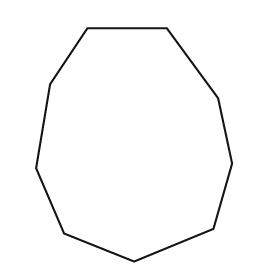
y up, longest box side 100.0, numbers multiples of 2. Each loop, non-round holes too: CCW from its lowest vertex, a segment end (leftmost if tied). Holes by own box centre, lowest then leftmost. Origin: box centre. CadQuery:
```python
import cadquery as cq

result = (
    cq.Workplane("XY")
    .moveTo(0.0, -50.0)
    .lineTo(34.0, -36.0)
    .lineTo(42.0, -8.0)
    .lineTo(36.0, 20.0)
    .lineTo(14.0, 50.0)
    .lineTo(-20.0, 50.0)
    .lineTo(-36.0, 26.0)
    .lineTo(-42.0, -10.0)
    .lineTo(-30.0, -38.0)
    .close()
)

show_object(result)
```